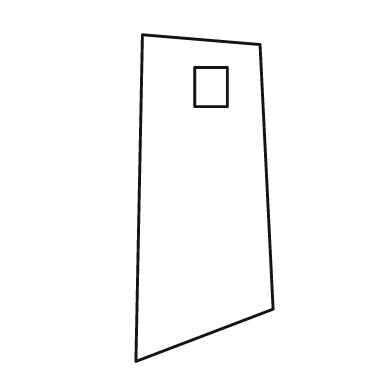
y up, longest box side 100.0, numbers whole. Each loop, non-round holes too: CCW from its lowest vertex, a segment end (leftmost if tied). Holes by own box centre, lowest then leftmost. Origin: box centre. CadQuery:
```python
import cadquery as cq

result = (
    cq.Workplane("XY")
    .moveTo(-21.0, -50.0)
    .lineTo(21.0, -34.0)
    .lineTo(17.0, 47.0)
    .lineTo(-19.0, 50.0)
    .close()
    .moveTo(-3.0, 28.0)
    .lineTo(7.0, 28.0)
    .lineTo(7.0, 40.0)
    .lineTo(-3.0, 40.0)
    .close()
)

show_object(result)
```